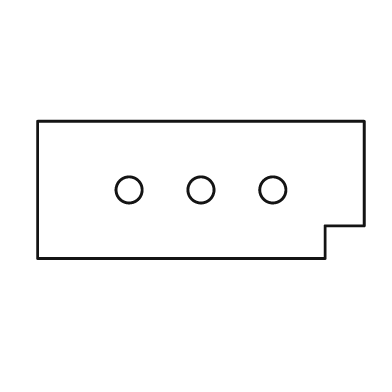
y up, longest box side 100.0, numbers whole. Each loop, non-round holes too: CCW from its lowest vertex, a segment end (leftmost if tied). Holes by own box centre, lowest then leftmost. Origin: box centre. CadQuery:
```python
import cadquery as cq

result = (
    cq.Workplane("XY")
    .moveTo(-50.0, -21.0)
    .lineTo(38.0, -21.0)
    .lineTo(38.0, -11.0)
    .lineTo(50.0, -11.0)
    .lineTo(50.0, 21.0)
    .lineTo(-50.0, 21.0)
    .close()
    .moveTo(-22.0, 0.0)
    .circle(4.0)
    .moveTo(0.0, 0.0)
    .circle(4.0)
    .moveTo(22.0, 0.0)
    .circle(4.0)
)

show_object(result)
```